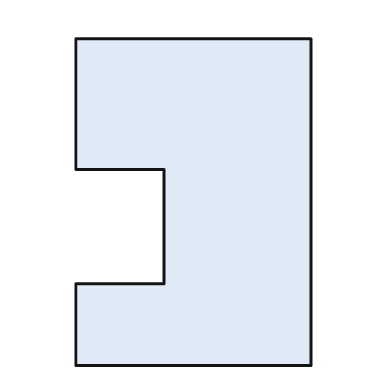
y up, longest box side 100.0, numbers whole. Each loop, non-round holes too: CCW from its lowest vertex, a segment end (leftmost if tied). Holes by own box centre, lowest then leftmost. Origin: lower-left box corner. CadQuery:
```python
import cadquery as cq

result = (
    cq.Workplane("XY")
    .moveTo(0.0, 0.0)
    .lineTo(72.0, 0.0)
    .lineTo(72.0, 100.0)
    .lineTo(0.0, 100.0)
    .lineTo(0.0, 60.0)
    .lineTo(27.0, 60.0)
    .lineTo(27.0, 25.0)
    .lineTo(0.0, 25.0)
    .close()
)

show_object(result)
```